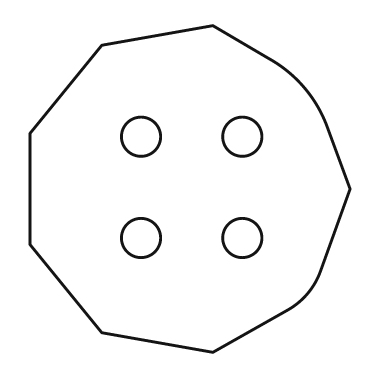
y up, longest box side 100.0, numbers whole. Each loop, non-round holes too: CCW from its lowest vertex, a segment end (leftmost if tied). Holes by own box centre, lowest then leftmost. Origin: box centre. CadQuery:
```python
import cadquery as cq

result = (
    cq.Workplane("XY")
    .moveTo(7.0, -50.0)
    .lineTo(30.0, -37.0)
    .threePointArc((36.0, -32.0), (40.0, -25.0))
    .lineTo(49.0, 0.0)
    .lineTo(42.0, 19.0)
    .threePointArc((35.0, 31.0), (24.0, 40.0))
    .lineTo(7.0, 50.0)
    .lineTo(-27.0, 44.0)
    .lineTo(-49.0, 17.0)
    .lineTo(-49.0, -17.0)
    .lineTo(-27.0, -44.0)
    .close()
    .moveTo(-15.0, -15.0)
    .circle(6.0)
    .moveTo(16.0, -15.0)
    .circle(6.0)
    .moveTo(-15.0, 16.0)
    .circle(6.0)
    .moveTo(16.0, 16.0)
    .circle(6.0)
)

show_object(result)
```